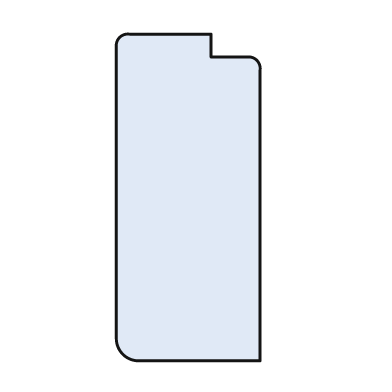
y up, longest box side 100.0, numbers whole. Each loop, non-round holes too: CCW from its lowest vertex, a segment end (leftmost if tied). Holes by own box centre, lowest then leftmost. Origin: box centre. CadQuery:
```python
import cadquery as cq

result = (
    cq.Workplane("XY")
    .moveTo(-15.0, -50.0)
    .lineTo(22.0, -50.0)
    .lineTo(22.0, 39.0)
    .threePointArc((21.0, 42.0), (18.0, 43.0))
    .lineTo(7.0, 43.0)
    .lineTo(7.0, 50.0)
    .lineTo(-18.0, 50.0)
    .threePointArc((-21.0, 49.0), (-22.0, 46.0))
    .lineTo(-22.0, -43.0)
    .threePointArc((-20.0, -48.0), (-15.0, -50.0))
    .close()
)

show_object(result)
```